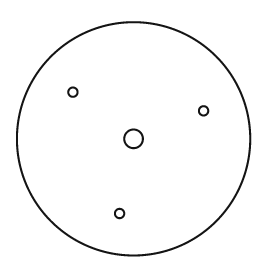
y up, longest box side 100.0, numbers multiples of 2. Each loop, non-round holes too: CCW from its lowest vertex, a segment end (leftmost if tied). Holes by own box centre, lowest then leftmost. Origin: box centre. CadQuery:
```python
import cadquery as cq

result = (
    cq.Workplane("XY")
    .moveTo(0.0, 0.0)
    .circle(50.0)
    .moveTo(-6.0, -32.0)
    .circle(2.0)
    .moveTo(0.0, 0.0)
    .circle(4.0)
    .moveTo(30.0, 12.0)
    .circle(2.0)
    .moveTo(-26.0, 20.0)
    .circle(2.0)
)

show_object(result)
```